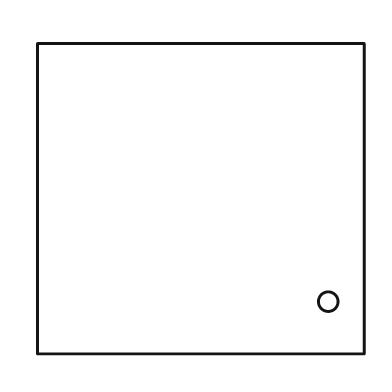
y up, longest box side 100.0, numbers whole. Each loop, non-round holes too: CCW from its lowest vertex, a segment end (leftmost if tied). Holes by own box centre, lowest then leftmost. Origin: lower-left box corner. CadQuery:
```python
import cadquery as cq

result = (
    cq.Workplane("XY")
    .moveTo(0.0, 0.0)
    .lineTo(100.0, 0.0)
    .lineTo(100.0, 95.0)
    .lineTo(0.0, 95.0)
    .close()
    .moveTo(89.0, 16.0)
    .circle(3.0)
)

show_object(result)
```